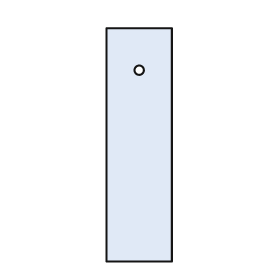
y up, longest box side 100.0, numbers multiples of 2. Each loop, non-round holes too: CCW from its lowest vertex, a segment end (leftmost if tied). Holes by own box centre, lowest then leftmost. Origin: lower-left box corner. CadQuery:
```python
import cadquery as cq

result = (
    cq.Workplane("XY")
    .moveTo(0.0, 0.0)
    .lineTo(28.0, 0.0)
    .lineTo(28.0, 100.0)
    .lineTo(0.0, 100.0)
    .close()
    .moveTo(14.0, 82.0)
    .circle(2.0)
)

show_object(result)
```